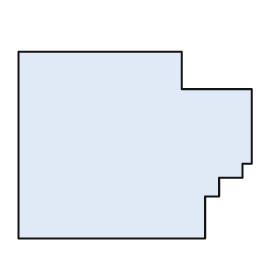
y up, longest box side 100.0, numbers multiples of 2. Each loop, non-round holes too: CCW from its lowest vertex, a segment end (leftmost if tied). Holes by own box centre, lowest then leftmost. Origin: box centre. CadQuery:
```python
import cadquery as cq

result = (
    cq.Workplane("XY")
    .moveTo(-50.0, -40.0)
    .lineTo(30.0, -40.0)
    .lineTo(30.0, -22.0)
    .lineTo(36.0, -22.0)
    .lineTo(36.0, -14.0)
    .lineTo(46.0, -14.0)
    .lineTo(46.0, -8.0)
    .lineTo(50.0, -8.0)
    .lineTo(50.0, 24.0)
    .lineTo(20.0, 24.0)
    .lineTo(20.0, 40.0)
    .lineTo(-50.0, 40.0)
    .close()
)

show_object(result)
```